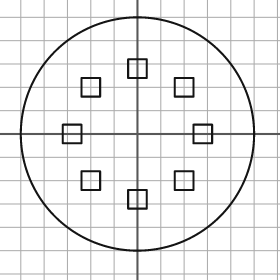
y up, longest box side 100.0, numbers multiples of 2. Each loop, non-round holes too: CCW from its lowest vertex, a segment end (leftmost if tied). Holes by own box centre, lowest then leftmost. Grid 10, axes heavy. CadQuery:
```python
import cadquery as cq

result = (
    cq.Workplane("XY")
    .moveTo(0.0, 0.0)
    .circle(50.0)
    .moveTo(-4.0, -32.0)
    .lineTo(4.0, -32.0)
    .lineTo(4.0, -24.0)
    .lineTo(-4.0, -24.0)
    .close()
    .moveTo(-24.0, -24.0)
    .lineTo(-16.0, -24.0)
    .lineTo(-16.0, -16.0)
    .lineTo(-24.0, -16.0)
    .close()
    .moveTo(16.0, -24.0)
    .lineTo(24.0, -24.0)
    .lineTo(24.0, -16.0)
    .lineTo(16.0, -16.0)
    .close()
    .moveTo(-32.0, -4.0)
    .lineTo(-24.0, -4.0)
    .lineTo(-24.0, 4.0)
    .lineTo(-32.0, 4.0)
    .close()
    .moveTo(24.0, -4.0)
    .lineTo(32.0, -4.0)
    .lineTo(32.0, 4.0)
    .lineTo(24.0, 4.0)
    .close()
    .moveTo(-24.0, 16.0)
    .lineTo(-16.0, 16.0)
    .lineTo(-16.0, 24.0)
    .lineTo(-24.0, 24.0)
    .close()
    .moveTo(16.0, 16.0)
    .lineTo(24.0, 16.0)
    .lineTo(24.0, 24.0)
    .lineTo(16.0, 24.0)
    .close()
    .moveTo(-4.0, 24.0)
    .lineTo(4.0, 24.0)
    .lineTo(4.0, 32.0)
    .lineTo(-4.0, 32.0)
    .close()
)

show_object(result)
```